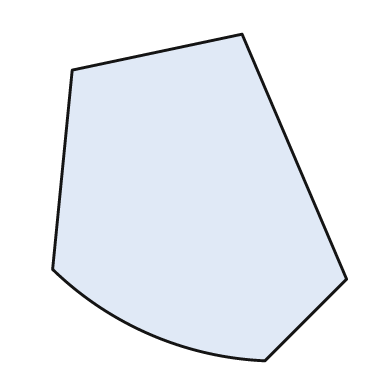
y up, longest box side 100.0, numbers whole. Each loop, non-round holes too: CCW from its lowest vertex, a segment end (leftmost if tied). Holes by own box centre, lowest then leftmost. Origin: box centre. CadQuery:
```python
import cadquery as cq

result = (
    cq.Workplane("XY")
    .moveTo(20.0, -50.0)
    .lineTo(45.0, -25.0)
    .lineTo(13.0, 50.0)
    .lineTo(-39.0, 39.0)
    .lineTo(-45.0, -22.0)
    .threePointArc((-15.0, -42.0), (20.0, -50.0))
    .close()
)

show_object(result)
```